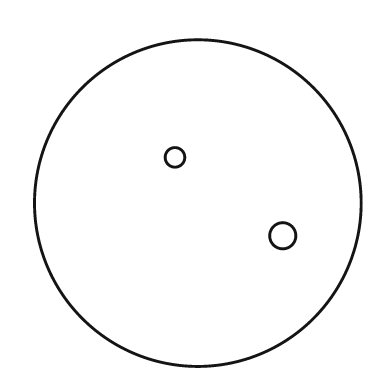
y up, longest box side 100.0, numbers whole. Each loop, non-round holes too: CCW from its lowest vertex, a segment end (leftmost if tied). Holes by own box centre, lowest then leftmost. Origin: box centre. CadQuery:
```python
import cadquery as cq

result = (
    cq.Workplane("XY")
    .moveTo(0.0, 0.0)
    .circle(50.0)
    .moveTo(26.0, -10.0)
    .circle(4.0)
    .moveTo(-7.0, 14.0)
    .circle(3.0)
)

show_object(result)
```